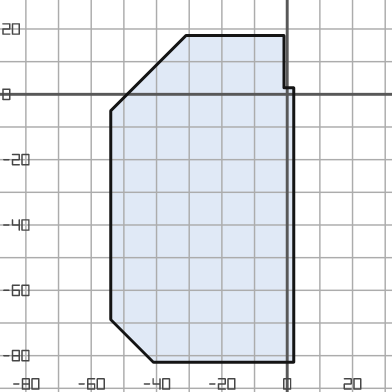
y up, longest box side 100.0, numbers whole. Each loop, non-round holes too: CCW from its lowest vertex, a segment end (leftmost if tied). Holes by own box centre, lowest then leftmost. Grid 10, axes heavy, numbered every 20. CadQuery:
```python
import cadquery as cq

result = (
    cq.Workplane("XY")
    .moveTo(-41.0, -82.0)
    .lineTo(2.0, -82.0)
    .lineTo(2.0, 2.0)
    .lineTo(-1.0, 2.0)
    .lineTo(-1.0, 18.0)
    .lineTo(-31.0, 18.0)
    .lineTo(-54.0, -5.0)
    .lineTo(-54.0, -69.0)
    .close()
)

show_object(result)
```